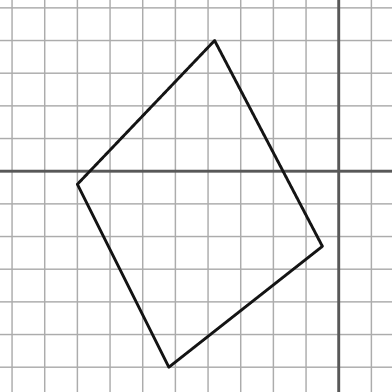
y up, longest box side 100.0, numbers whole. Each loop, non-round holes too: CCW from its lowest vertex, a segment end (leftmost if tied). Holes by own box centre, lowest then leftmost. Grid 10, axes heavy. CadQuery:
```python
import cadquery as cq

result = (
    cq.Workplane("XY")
    .moveTo(-52.0, -60.0)
    .lineTo(-5.0, -23.0)
    .lineTo(-38.0, 40.0)
    .lineTo(-80.0, -4.0)
    .close()
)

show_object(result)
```